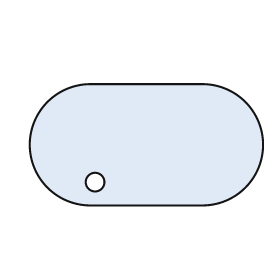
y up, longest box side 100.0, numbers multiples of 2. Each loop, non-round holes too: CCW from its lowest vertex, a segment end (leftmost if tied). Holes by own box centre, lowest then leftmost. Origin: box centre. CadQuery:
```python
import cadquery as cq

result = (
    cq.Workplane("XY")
    .moveTo(-24.0, -26.0)
    .lineTo(24.0, -26.0)
    .threePointArc((50.0, 0.0), (24.0, 26.0))
    .lineTo(-24.0, 26.0)
    .threePointArc((-50.0, 0.0), (-24.0, -26.0))
    .close()
    .moveTo(-22.0, -16.0)
    .circle(4.0)
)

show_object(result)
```